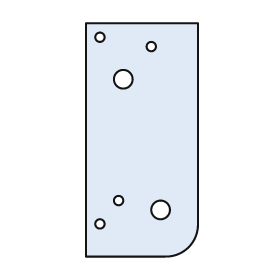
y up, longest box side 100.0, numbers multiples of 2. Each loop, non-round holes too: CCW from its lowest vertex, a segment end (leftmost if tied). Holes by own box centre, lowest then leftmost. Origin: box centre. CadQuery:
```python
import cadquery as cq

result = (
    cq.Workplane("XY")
    .moveTo(-24.0, -50.0)
    .lineTo(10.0, -50.0)
    .threePointArc((20.0, -46.0), (24.0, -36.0))
    .lineTo(24.0, 50.0)
    .lineTo(-24.0, 50.0)
    .close()
    .moveTo(-18.0, -36.0)
    .circle(2.0)
    .moveTo(8.0, -30.0)
    .circle(4.0)
    .moveTo(-10.0, -26.0)
    .circle(2.0)
    .moveTo(-8.0, 26.0)
    .circle(4.0)
    .moveTo(4.0, 40.0)
    .circle(2.0)
    .moveTo(-18.0, 44.0)
    .circle(2.0)
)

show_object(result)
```